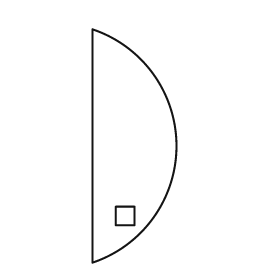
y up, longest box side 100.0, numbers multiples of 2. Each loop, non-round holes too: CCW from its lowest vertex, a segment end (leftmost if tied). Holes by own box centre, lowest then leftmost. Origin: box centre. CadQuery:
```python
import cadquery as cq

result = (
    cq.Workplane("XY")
    .moveTo(-18.0, -50.0)
    .threePointArc((18.0, 0.0), (-18.0, 50.0))
    .close()
    .moveTo(-8.0, -34.0)
    .lineTo(0.0, -34.0)
    .lineTo(0.0, -26.0)
    .lineTo(-8.0, -26.0)
    .close()
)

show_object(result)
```